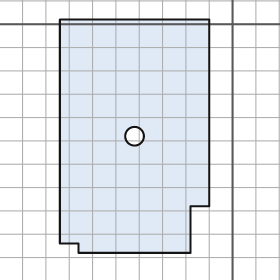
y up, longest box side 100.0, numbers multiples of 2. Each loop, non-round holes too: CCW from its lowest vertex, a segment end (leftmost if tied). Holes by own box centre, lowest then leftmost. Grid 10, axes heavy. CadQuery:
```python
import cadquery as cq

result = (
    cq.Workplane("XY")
    .moveTo(-66.0, -98.0)
    .lineTo(-18.0, -98.0)
    .lineTo(-18.0, -78.0)
    .lineTo(-10.0, -78.0)
    .lineTo(-10.0, 2.0)
    .lineTo(-74.0, 2.0)
    .lineTo(-74.0, -94.0)
    .lineTo(-66.0, -94.0)
    .close()
    .moveTo(-42.0, -48.0)
    .circle(4.0)
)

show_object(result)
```